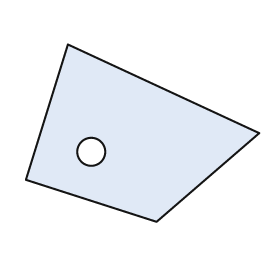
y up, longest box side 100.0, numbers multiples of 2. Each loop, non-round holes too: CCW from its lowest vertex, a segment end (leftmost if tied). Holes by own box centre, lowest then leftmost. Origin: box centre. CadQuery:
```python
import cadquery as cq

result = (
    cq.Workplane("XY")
    .moveTo(6.0, -38.0)
    .lineTo(50.0, 0.0)
    .lineTo(-32.0, 38.0)
    .lineTo(-50.0, -20.0)
    .close()
    .moveTo(-22.0, -8.0)
    .circle(6.0)
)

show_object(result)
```